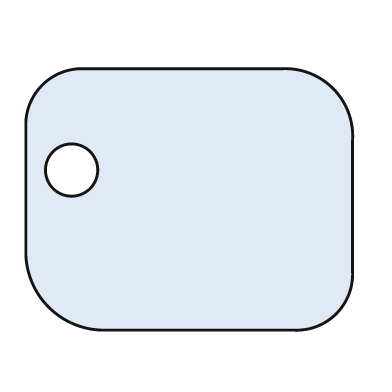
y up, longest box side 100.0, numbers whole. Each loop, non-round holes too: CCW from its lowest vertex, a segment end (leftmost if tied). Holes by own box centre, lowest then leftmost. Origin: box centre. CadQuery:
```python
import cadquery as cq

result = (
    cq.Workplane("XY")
    .moveTo(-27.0, -40.0)
    .lineTo(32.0, -40.0)
    .threePointArc((45.0, -35.0), (50.0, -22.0))
    .lineTo(50.0, 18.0)
    .threePointArc((44.0, 34.0), (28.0, 40.0))
    .lineTo(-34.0, 40.0)
    .threePointArc((-45.0, 35.0), (-50.0, 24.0))
    .lineTo(-50.0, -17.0)
    .threePointArc((-43.0, -33.0), (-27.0, -40.0))
    .close()
    .moveTo(-36.0, 9.0)
    .circle(8.0)
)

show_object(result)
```